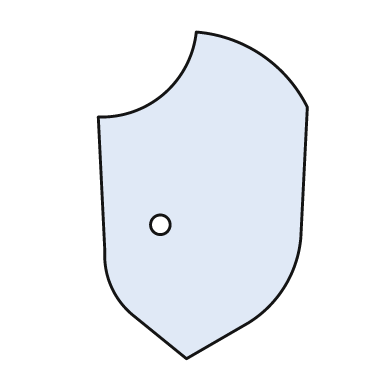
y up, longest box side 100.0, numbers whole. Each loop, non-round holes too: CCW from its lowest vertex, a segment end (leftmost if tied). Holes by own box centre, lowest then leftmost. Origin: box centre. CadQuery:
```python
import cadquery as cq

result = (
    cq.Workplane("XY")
    .moveTo(-5.0, -50.0)
    .lineTo(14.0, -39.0)
    .threePointArc((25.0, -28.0), (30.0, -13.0))
    .lineTo(32.0, 27.0)
    .threePointArc((18.0, 43.0), (-2.0, 50.0))
    .threePointArc((-12.0, 31.0), (-32.0, 24.0))
    .lineTo(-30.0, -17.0)
    .threePointArc((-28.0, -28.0), (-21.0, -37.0))
    .close()
    .moveTo(-13.0, -9.0)
    .circle(3.0)
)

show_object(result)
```